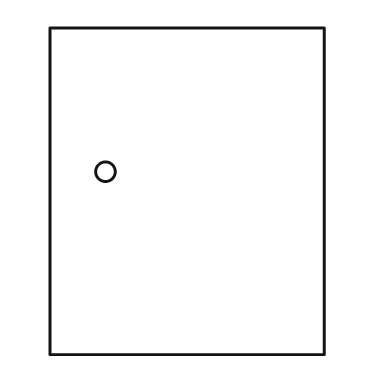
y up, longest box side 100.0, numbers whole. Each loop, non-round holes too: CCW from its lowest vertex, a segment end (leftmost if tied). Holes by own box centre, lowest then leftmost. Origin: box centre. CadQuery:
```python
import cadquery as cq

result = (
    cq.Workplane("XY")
    .moveTo(-42.0, -50.0)
    .lineTo(42.0, -50.0)
    .lineTo(42.0, 50.0)
    .lineTo(-42.0, 50.0)
    .close()
    .moveTo(-25.0, 6.0)
    .circle(3.0)
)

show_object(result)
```